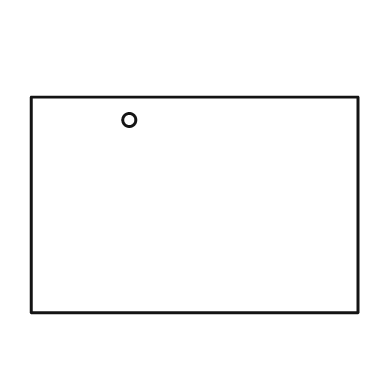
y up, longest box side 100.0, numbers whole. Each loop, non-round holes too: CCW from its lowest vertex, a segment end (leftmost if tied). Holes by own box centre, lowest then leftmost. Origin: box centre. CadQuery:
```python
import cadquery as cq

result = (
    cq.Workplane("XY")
    .moveTo(-50.0, -33.0)
    .lineTo(50.0, -33.0)
    .lineTo(50.0, 33.0)
    .lineTo(-50.0, 33.0)
    .close()
    .moveTo(-20.0, 26.0)
    .circle(2.0)
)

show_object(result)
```